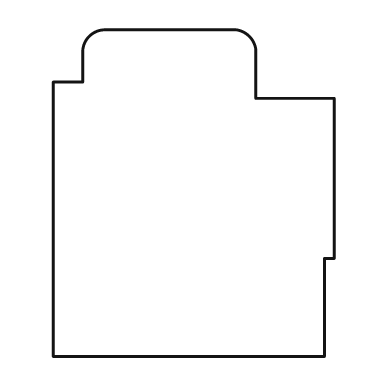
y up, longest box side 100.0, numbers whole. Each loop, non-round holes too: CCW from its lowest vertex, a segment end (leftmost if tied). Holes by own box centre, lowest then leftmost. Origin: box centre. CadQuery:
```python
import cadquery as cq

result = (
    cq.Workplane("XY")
    .moveTo(-43.0, -50.0)
    .lineTo(40.0, -50.0)
    .lineTo(40.0, -20.0)
    .lineTo(43.0, -20.0)
    .lineTo(43.0, 29.0)
    .lineTo(19.0, 29.0)
    .lineTo(19.0, 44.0)
    .threePointArc((17.0, 48.0), (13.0, 50.0))
    .lineTo(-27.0, 50.0)
    .threePointArc((-32.0, 48.0), (-34.0, 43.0))
    .lineTo(-34.0, 34.0)
    .lineTo(-43.0, 34.0)
    .close()
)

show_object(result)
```